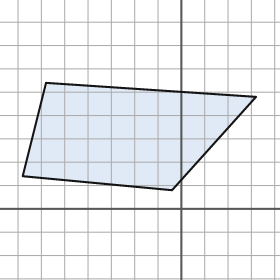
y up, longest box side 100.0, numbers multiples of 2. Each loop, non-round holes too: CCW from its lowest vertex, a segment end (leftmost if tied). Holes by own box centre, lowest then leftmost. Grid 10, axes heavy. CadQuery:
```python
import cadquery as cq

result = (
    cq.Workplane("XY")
    .moveTo(-4.0, 8.0)
    .lineTo(32.0, 48.0)
    .lineTo(-58.0, 54.0)
    .lineTo(-68.0, 14.0)
    .close()
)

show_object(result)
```